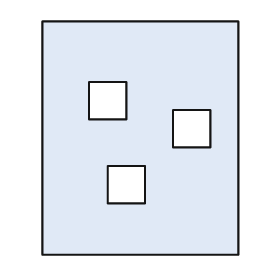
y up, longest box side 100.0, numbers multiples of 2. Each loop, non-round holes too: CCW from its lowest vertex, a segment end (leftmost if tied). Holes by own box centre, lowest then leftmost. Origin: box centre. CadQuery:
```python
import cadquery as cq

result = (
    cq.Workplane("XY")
    .moveTo(-42.0, -50.0)
    .lineTo(42.0, -50.0)
    .lineTo(42.0, 50.0)
    .lineTo(-42.0, 50.0)
    .close()
    .moveTo(-14.0, -28.0)
    .lineTo(2.0, -28.0)
    .lineTo(2.0, -12.0)
    .lineTo(-14.0, -12.0)
    .close()
    .moveTo(14.0, -4.0)
    .lineTo(30.0, -4.0)
    .lineTo(30.0, 12.0)
    .lineTo(14.0, 12.0)
    .close()
    .moveTo(-22.0, 8.0)
    .lineTo(-6.0, 8.0)
    .lineTo(-6.0, 24.0)
    .lineTo(-22.0, 24.0)
    .close()
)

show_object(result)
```